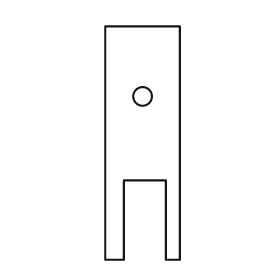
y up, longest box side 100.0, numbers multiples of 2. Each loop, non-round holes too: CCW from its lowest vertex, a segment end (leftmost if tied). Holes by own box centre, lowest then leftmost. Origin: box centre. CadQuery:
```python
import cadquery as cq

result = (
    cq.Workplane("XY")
    .moveTo(-16.0, -50.0)
    .lineTo(-8.0, -50.0)
    .lineTo(-8.0, -16.0)
    .lineTo(10.0, -16.0)
    .lineTo(10.0, -50.0)
    .lineTo(16.0, -50.0)
    .lineTo(16.0, 50.0)
    .lineTo(-16.0, 50.0)
    .close()
    .moveTo(0.0, 20.0)
    .circle(4.0)
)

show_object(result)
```